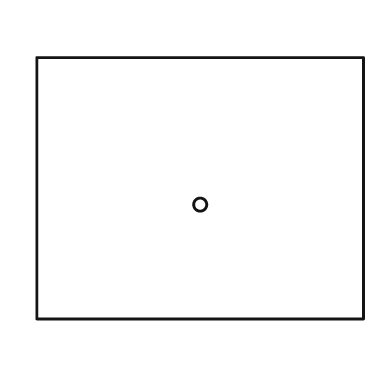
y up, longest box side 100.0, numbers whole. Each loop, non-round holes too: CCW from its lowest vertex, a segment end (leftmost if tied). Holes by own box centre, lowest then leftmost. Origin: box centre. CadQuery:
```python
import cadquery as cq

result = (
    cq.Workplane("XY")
    .moveTo(-50.0, -40.0)
    .lineTo(50.0, -40.0)
    .lineTo(50.0, 40.0)
    .lineTo(-50.0, 40.0)
    .close()
    .moveTo(0.0, -5.0)
    .circle(2.0)
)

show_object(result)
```